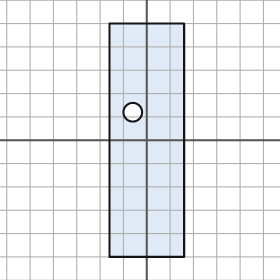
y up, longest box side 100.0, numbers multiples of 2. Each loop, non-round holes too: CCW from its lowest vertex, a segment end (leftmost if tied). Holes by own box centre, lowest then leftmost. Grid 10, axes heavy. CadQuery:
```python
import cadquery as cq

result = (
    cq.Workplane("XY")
    .moveTo(-16.0, -50.0)
    .lineTo(16.0, -50.0)
    .lineTo(16.0, 50.0)
    .lineTo(-16.0, 50.0)
    .close()
    .moveTo(-6.0, 12.0)
    .circle(4.0)
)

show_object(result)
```